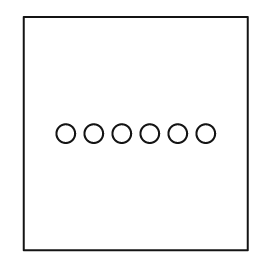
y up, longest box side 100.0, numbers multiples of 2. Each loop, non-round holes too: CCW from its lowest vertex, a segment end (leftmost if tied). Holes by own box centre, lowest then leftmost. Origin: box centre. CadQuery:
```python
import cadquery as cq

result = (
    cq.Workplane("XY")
    .moveTo(-48.0, -50.0)
    .lineTo(48.0, -50.0)
    .lineTo(48.0, 50.0)
    .lineTo(-48.0, 50.0)
    .close()
    .moveTo(-30.0, 0.0)
    .circle(4.0)
    .moveTo(-18.0, 0.0)
    .circle(4.0)
    .moveTo(-6.0, 0.0)
    .circle(4.0)
    .moveTo(6.0, 0.0)
    .circle(4.0)
    .moveTo(18.0, 0.0)
    .circle(4.0)
    .moveTo(30.0, 0.0)
    .circle(4.0)
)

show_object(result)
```